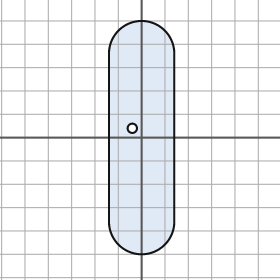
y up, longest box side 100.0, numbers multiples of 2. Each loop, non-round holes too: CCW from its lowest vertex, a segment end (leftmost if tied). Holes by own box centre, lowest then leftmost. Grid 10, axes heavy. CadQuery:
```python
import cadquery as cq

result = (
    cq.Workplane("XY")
    .moveTo(-14.0, -36.0)
    .threePointArc((0.0, -50.0), (14.0, -36.0))
    .lineTo(14.0, 36.0)
    .threePointArc((0.0, 50.0), (-14.0, 36.0))
    .close()
    .moveTo(-4.0, 4.0)
    .circle(2.0)
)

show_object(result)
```